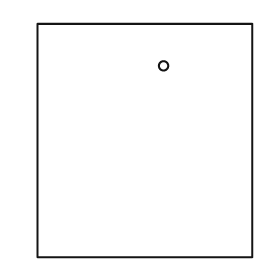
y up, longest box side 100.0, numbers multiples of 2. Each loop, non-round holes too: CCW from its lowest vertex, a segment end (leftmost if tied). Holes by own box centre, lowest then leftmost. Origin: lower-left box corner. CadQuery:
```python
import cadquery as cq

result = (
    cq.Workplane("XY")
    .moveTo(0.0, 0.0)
    .lineTo(92.0, 0.0)
    .lineTo(92.0, 100.0)
    .lineTo(0.0, 100.0)
    .close()
    .moveTo(54.0, 82.0)
    .circle(2.0)
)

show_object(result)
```